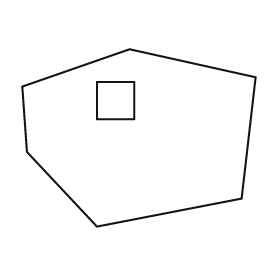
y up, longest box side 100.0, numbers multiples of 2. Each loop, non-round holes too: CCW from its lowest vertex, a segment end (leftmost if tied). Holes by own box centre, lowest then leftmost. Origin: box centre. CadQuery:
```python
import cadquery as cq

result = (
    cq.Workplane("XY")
    .moveTo(-18.0, -38.0)
    .lineTo(44.0, -26.0)
    .lineTo(50.0, 26.0)
    .lineTo(-4.0, 38.0)
    .lineTo(-50.0, 22.0)
    .lineTo(-48.0, -6.0)
    .close()
    .moveTo(-18.0, 8.0)
    .lineTo(-2.0, 8.0)
    .lineTo(-2.0, 24.0)
    .lineTo(-18.0, 24.0)
    .close()
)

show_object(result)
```